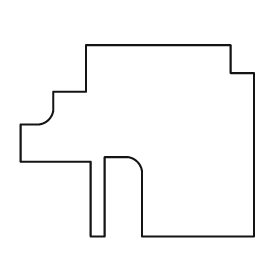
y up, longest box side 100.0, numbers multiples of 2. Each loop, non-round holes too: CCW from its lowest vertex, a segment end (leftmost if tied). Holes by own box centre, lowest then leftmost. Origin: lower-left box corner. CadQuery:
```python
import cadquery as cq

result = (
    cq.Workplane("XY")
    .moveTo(30.0, 0.0)
    .lineTo(36.0, 0.0)
    .lineTo(36.0, 34.0)
    .lineTo(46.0, 34.0)
    .threePointArc((50.0, 32.0), (52.0, 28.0))
    .lineTo(52.0, 0.0)
    .lineTo(100.0, 0.0)
    .lineTo(100.0, 70.0)
    .lineTo(90.0, 70.0)
    .lineTo(90.0, 82.0)
    .lineTo(28.0, 82.0)
    .lineTo(28.0, 62.0)
    .lineTo(14.0, 62.0)
    .lineTo(14.0, 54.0)
    .threePointArc((12.0, 50.0), (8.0, 48.0))
    .lineTo(0.0, 48.0)
    .lineTo(0.0, 32.0)
    .lineTo(30.0, 32.0)
    .close()
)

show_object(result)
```